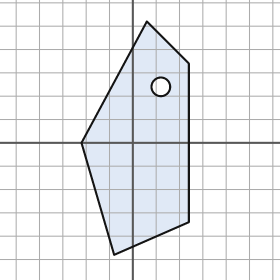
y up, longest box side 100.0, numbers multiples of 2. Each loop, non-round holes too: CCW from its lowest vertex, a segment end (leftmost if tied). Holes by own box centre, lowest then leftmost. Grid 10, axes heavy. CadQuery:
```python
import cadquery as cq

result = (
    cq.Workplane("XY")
    .moveTo(-8.0, -48.0)
    .lineTo(24.0, -34.0)
    .lineTo(24.0, 34.0)
    .lineTo(6.0, 52.0)
    .lineTo(-22.0, 0.0)
    .close()
    .moveTo(12.0, 24.0)
    .circle(4.0)
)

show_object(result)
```